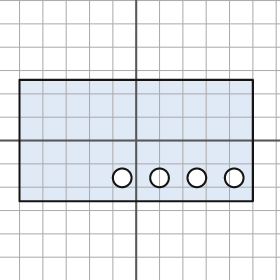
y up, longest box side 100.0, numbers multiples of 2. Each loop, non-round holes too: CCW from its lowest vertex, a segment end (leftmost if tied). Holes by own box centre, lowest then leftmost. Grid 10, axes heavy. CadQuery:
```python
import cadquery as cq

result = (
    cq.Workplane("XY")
    .moveTo(-50.0, -26.0)
    .lineTo(50.0, -26.0)
    .lineTo(50.0, 26.0)
    .lineTo(-50.0, 26.0)
    .close()
    .moveTo(-6.0, -16.0)
    .circle(4.0)
    .moveTo(10.0, -16.0)
    .circle(4.0)
    .moveTo(26.0, -16.0)
    .circle(4.0)
    .moveTo(42.0, -16.0)
    .circle(4.0)
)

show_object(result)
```